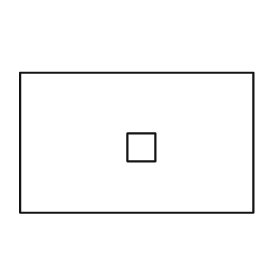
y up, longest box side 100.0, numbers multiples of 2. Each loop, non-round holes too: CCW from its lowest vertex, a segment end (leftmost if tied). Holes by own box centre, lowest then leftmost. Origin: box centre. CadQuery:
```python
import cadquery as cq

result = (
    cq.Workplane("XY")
    .moveTo(-50.0, -30.0)
    .lineTo(50.0, -30.0)
    .lineTo(50.0, 30.0)
    .lineTo(-50.0, 30.0)
    .close()
    .moveTo(-4.0, -8.0)
    .lineTo(8.0, -8.0)
    .lineTo(8.0, 4.0)
    .lineTo(-4.0, 4.0)
    .close()
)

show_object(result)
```